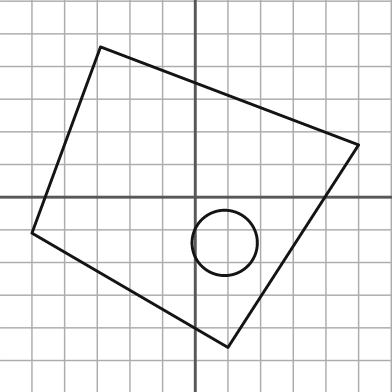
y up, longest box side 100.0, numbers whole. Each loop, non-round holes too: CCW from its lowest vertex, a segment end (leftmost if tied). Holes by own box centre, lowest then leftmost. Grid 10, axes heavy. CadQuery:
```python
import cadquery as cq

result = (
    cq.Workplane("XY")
    .moveTo(10.0, -46.0)
    .lineTo(50.0, 16.0)
    .lineTo(-29.0, 46.0)
    .lineTo(-50.0, -11.0)
    .close()
    .moveTo(9.0, -14.0)
    .circle(10.0)
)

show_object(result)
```